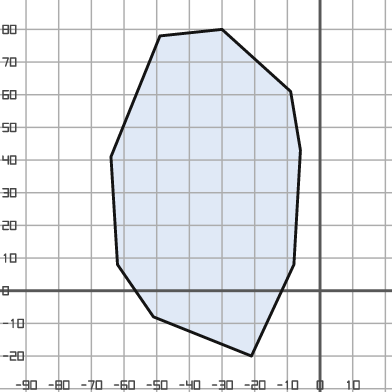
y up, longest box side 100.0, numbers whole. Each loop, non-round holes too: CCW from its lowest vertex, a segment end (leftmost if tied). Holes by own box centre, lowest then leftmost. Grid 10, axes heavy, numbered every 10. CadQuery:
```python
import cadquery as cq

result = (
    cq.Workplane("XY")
    .moveTo(-21.0, -20.0)
    .lineTo(-8.0, 8.0)
    .lineTo(-6.0, 43.0)
    .lineTo(-9.0, 61.0)
    .lineTo(-30.0, 80.0)
    .lineTo(-49.0, 78.0)
    .lineTo(-64.0, 41.0)
    .lineTo(-62.0, 8.0)
    .lineTo(-51.0, -8.0)
    .close()
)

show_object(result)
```